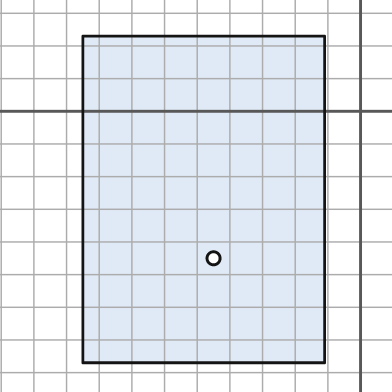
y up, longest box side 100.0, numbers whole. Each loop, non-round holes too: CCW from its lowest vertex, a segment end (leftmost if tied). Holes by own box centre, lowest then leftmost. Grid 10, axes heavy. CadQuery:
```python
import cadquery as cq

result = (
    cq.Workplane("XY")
    .moveTo(-85.0, -77.0)
    .lineTo(-11.0, -77.0)
    .lineTo(-11.0, 23.0)
    .lineTo(-85.0, 23.0)
    .close()
    .moveTo(-45.0, -45.0)
    .circle(2.0)
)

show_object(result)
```